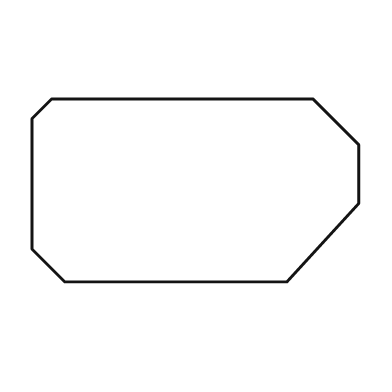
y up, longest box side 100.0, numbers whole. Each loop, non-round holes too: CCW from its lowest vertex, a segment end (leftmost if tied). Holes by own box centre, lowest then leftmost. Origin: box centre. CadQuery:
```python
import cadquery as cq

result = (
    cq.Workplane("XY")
    .moveTo(-40.0, -28.0)
    .lineTo(28.0, -28.0)
    .lineTo(50.0, -4.0)
    .lineTo(50.0, 14.0)
    .lineTo(36.0, 28.0)
    .lineTo(-44.0, 28.0)
    .lineTo(-50.0, 22.0)
    .lineTo(-50.0, -18.0)
    .close()
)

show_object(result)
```